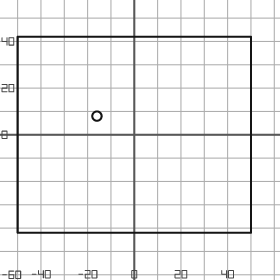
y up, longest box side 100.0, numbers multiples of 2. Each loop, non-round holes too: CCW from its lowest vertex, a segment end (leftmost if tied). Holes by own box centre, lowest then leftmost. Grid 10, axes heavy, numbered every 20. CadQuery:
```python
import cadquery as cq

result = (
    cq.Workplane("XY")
    .moveTo(-50.0, -42.0)
    .lineTo(50.0, -42.0)
    .lineTo(50.0, 42.0)
    .lineTo(-50.0, 42.0)
    .close()
    .moveTo(-16.0, 8.0)
    .circle(2.0)
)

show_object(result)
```